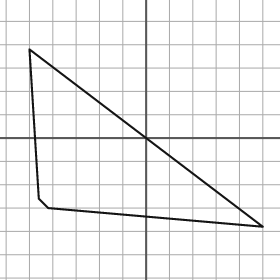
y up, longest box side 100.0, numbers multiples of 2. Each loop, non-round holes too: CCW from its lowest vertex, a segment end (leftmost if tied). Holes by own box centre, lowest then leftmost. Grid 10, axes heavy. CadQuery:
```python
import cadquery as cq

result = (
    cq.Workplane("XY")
    .moveTo(50.0, -38.0)
    .lineTo(-50.0, 38.0)
    .lineTo(-46.0, -26.0)
    .lineTo(-42.0, -30.0)
    .close()
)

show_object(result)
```